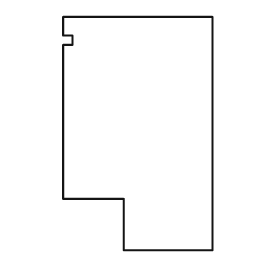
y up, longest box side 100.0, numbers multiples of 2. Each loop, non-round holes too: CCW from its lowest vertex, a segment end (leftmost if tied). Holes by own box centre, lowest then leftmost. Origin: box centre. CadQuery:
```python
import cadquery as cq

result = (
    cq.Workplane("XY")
    .moveTo(-6.0, -50.0)
    .lineTo(32.0, -50.0)
    .lineTo(32.0, 50.0)
    .lineTo(-32.0, 50.0)
    .lineTo(-32.0, 42.0)
    .lineTo(-28.0, 42.0)
    .lineTo(-28.0, 38.0)
    .lineTo(-32.0, 38.0)
    .lineTo(-32.0, -28.0)
    .lineTo(-6.0, -28.0)
    .close()
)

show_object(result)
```